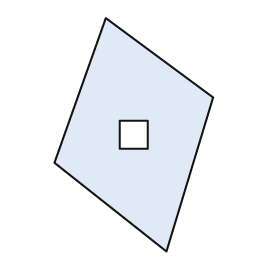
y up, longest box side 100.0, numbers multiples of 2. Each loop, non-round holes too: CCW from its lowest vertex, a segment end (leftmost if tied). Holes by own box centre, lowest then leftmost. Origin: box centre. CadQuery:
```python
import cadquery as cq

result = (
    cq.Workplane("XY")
    .moveTo(14.0, -50.0)
    .lineTo(34.0, 16.0)
    .lineTo(-12.0, 50.0)
    .lineTo(-34.0, -12.0)
    .close()
    .moveTo(-6.0, -6.0)
    .lineTo(6.0, -6.0)
    .lineTo(6.0, 6.0)
    .lineTo(-6.0, 6.0)
    .close()
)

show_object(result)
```